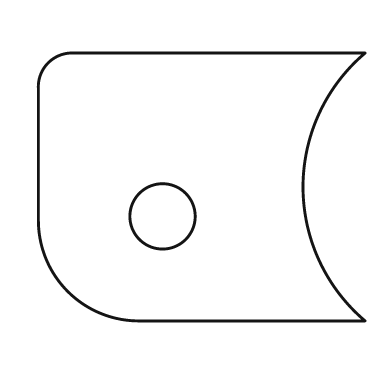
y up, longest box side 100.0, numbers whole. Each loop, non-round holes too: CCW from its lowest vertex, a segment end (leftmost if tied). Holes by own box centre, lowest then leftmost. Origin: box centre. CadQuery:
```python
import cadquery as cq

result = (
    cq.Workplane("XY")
    .moveTo(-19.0, -41.0)
    .lineTo(50.0, -41.0)
    .threePointArc((31.0, 0.0), (50.0, 41.0))
    .lineTo(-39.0, 41.0)
    .threePointArc((-47.0, 38.0), (-50.0, 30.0))
    .lineTo(-50.0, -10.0)
    .threePointArc((-41.0, -32.0), (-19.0, -41.0))
    .close()
    .moveTo(-12.0, -9.0)
    .circle(10.0)
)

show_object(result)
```